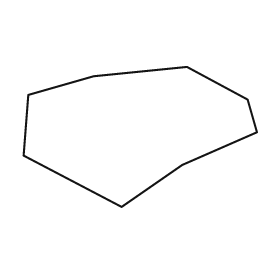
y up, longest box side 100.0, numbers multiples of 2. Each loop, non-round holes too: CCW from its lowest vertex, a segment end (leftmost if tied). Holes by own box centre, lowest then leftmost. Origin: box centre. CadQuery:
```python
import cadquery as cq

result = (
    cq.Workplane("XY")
    .moveTo(-8.0, -30.0)
    .lineTo(18.0, -12.0)
    .lineTo(50.0, 2.0)
    .lineTo(46.0, 16.0)
    .lineTo(20.0, 30.0)
    .lineTo(-20.0, 26.0)
    .lineTo(-48.0, 18.0)
    .lineTo(-50.0, -8.0)
    .close()
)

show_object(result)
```